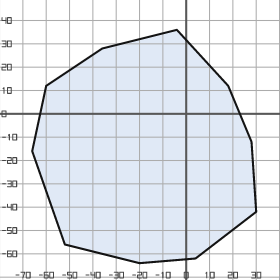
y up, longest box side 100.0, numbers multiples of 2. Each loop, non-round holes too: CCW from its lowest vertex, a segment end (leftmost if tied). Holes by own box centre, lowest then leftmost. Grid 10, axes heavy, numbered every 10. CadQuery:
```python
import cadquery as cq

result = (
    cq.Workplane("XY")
    .moveTo(-20.0, -64.0)
    .lineTo(4.0, -62.0)
    .lineTo(30.0, -42.0)
    .lineTo(28.0, -12.0)
    .lineTo(18.0, 12.0)
    .lineTo(-4.0, 36.0)
    .lineTo(-36.0, 28.0)
    .lineTo(-60.0, 12.0)
    .lineTo(-66.0, -16.0)
    .lineTo(-52.0, -56.0)
    .close()
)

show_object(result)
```